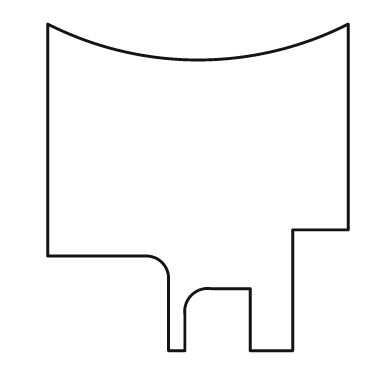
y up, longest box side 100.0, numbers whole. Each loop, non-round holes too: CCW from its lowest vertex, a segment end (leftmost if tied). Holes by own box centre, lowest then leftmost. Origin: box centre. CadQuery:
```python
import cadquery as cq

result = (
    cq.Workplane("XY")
    .moveTo(-9.0, -50.0)
    .lineTo(-4.0, -50.0)
    .lineTo(-4.0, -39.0)
    .threePointArc((-2.0, -33.0), (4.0, -31.0))
    .lineTo(16.0, -31.0)
    .lineTo(16.0, -50.0)
    .lineTo(29.0, -50.0)
    .lineTo(29.0, -13.0)
    .lineTo(46.0, -13.0)
    .lineTo(46.0, 50.0)
    .threePointArc((0.0, 39.0), (-46.0, 50.0))
    .lineTo(-46.0, -21.0)
    .lineTo(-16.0, -21.0)
    .threePointArc((-11.0, -23.0), (-9.0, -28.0))
    .close()
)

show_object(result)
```